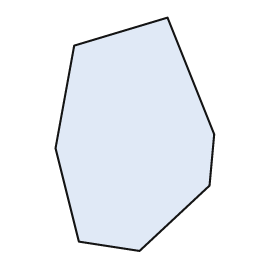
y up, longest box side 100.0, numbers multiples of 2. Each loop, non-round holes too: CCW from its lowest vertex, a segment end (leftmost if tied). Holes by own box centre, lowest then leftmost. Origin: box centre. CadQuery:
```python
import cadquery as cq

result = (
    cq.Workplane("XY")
    .moveTo(2.0, -50.0)
    .lineTo(32.0, -22.0)
    .lineTo(34.0, 0.0)
    .lineTo(14.0, 50.0)
    .lineTo(-26.0, 38.0)
    .lineTo(-34.0, -6.0)
    .lineTo(-24.0, -46.0)
    .close()
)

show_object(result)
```